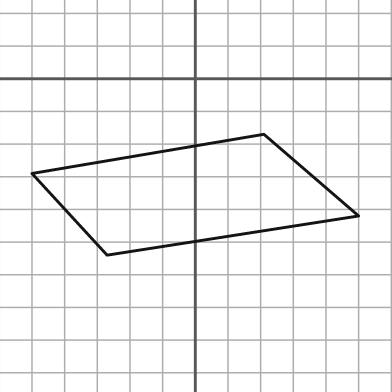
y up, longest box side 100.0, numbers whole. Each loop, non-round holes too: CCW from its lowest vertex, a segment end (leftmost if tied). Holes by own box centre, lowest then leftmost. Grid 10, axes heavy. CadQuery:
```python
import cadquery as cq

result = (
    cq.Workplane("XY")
    .moveTo(-27.0, -54.0)
    .lineTo(50.0, -42.0)
    .lineTo(21.0, -17.0)
    .lineTo(-50.0, -29.0)
    .close()
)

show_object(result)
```